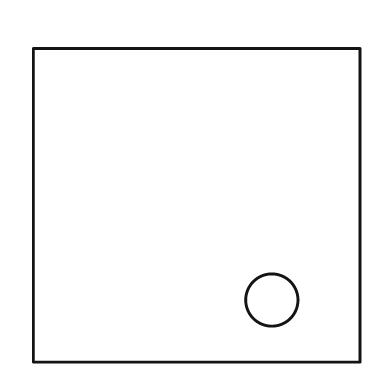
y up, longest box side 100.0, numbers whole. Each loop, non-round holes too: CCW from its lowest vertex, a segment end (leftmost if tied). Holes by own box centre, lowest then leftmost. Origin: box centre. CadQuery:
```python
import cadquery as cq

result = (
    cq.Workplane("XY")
    .moveTo(-50.0, -48.0)
    .lineTo(50.0, -48.0)
    .lineTo(50.0, 48.0)
    .lineTo(-50.0, 48.0)
    .close()
    .moveTo(23.0, -29.0)
    .circle(8.0)
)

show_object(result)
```